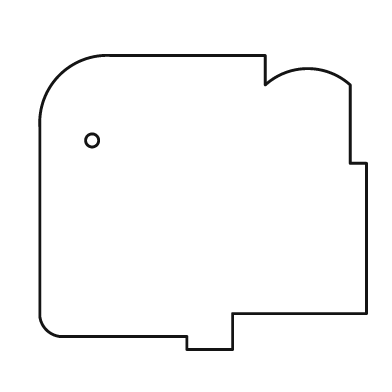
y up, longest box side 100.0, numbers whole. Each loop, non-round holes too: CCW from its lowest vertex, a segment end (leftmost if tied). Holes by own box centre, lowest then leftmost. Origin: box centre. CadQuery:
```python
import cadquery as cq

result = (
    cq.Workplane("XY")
    .moveTo(-5.0, -45.0)
    .lineTo(9.0, -45.0)
    .lineTo(9.0, -34.0)
    .lineTo(50.0, -34.0)
    .lineTo(50.0, 12.0)
    .lineTo(45.0, 12.0)
    .lineTo(45.0, 36.0)
    .threePointArc((32.0, 41.0), (19.0, 36.0))
    .lineTo(19.0, 45.0)
    .lineTo(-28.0, 45.0)
    .threePointArc((-44.0, 39.0), (-50.0, 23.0))
    .lineTo(-50.0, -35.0)
    .threePointArc((-48.0, -39.0), (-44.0, -41.0))
    .lineTo(-5.0, -41.0)
    .close()
    .moveTo(-34.0, 19.0)
    .circle(2.0)
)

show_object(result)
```